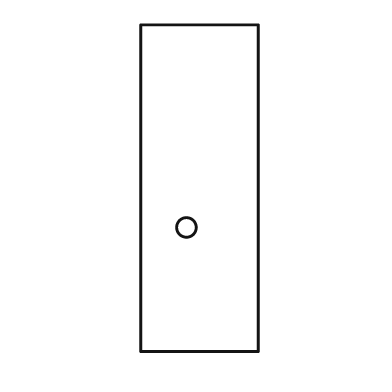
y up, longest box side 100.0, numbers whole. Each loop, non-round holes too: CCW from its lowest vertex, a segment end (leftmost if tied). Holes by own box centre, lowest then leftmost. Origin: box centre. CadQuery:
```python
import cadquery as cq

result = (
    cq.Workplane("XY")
    .moveTo(-18.0, -50.0)
    .lineTo(18.0, -50.0)
    .lineTo(18.0, 50.0)
    .lineTo(-18.0, 50.0)
    .close()
    .moveTo(-4.0, -12.0)
    .circle(3.0)
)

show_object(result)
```